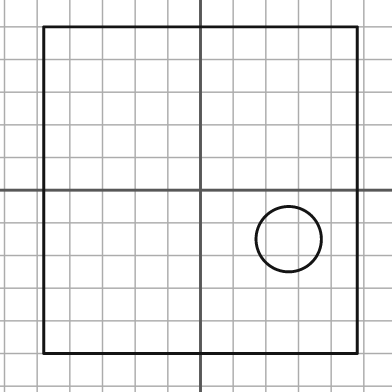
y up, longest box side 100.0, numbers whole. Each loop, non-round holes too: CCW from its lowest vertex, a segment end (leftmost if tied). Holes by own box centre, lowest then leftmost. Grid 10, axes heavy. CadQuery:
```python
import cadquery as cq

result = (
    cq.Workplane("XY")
    .moveTo(-48.0, -50.0)
    .lineTo(48.0, -50.0)
    .lineTo(48.0, 50.0)
    .lineTo(-48.0, 50.0)
    .close()
    .moveTo(27.0, -15.0)
    .circle(10.0)
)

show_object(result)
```